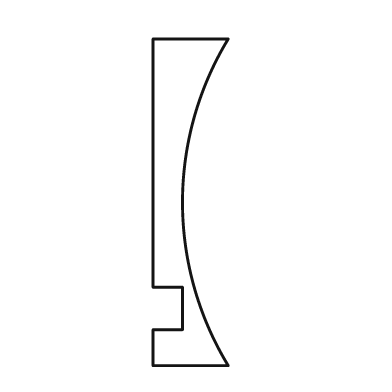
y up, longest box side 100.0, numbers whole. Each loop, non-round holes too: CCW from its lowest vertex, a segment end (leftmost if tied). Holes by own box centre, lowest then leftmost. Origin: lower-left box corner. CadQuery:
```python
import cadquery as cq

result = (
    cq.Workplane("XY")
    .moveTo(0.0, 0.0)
    .lineTo(23.0, 0.0)
    .threePointArc((9.0, 50.0), (23.0, 100.0))
    .lineTo(0.0, 100.0)
    .lineTo(0.0, 24.0)
    .lineTo(9.0, 24.0)
    .lineTo(9.0, 11.0)
    .lineTo(0.0, 11.0)
    .close()
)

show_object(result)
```